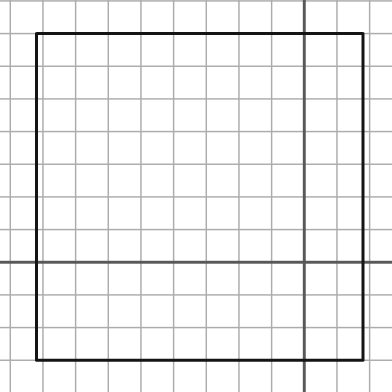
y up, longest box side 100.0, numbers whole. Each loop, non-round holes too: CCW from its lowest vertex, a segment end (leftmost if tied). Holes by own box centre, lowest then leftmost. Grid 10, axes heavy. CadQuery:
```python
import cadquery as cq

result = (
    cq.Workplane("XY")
    .moveTo(-82.0, -30.0)
    .lineTo(18.0, -30.0)
    .lineTo(18.0, 70.0)
    .lineTo(-82.0, 70.0)
    .close()
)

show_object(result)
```